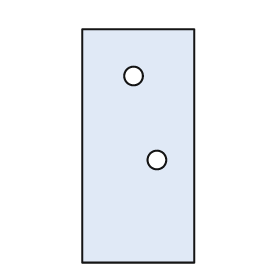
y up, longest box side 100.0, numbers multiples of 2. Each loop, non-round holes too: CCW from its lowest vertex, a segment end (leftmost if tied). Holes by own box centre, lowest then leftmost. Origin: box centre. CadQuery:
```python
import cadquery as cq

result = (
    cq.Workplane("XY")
    .moveTo(-24.0, -50.0)
    .lineTo(24.0, -50.0)
    .lineTo(24.0, 50.0)
    .lineTo(-24.0, 50.0)
    .close()
    .moveTo(8.0, -6.0)
    .circle(4.0)
    .moveTo(-2.0, 30.0)
    .circle(4.0)
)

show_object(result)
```